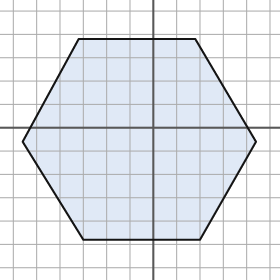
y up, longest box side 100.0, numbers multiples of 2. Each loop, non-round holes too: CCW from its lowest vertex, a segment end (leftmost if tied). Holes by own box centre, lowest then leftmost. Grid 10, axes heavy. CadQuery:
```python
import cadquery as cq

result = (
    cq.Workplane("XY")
    .moveTo(-30.0, -48.0)
    .lineTo(20.0, -48.0)
    .lineTo(44.0, -6.0)
    .lineTo(18.0, 38.0)
    .lineTo(-32.0, 38.0)
    .lineTo(-56.0, -6.0)
    .close()
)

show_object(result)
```